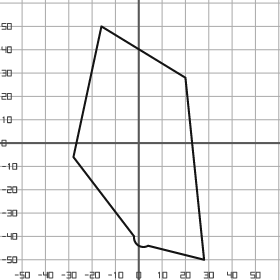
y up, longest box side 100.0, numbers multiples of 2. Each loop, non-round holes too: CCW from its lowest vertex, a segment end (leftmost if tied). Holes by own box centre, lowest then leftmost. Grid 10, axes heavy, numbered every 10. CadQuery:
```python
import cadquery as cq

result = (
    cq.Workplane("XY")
    .moveTo(28.0, -50.0)
    .lineTo(20.0, 28.0)
    .lineTo(-16.0, 50.0)
    .lineTo(-28.0, -6.0)
    .lineTo(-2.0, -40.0)
    .threePointArc((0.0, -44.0), (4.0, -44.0))
    .close()
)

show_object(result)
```